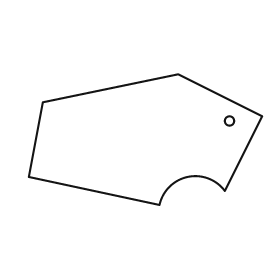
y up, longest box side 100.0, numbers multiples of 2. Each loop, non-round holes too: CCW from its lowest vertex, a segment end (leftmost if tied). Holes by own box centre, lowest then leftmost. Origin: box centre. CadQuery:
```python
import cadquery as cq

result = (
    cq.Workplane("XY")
    .moveTo(6.0, -28.0)
    .threePointArc((18.0, -16.0), (34.0, -22.0))
    .lineTo(50.0, 10.0)
    .lineTo(14.0, 28.0)
    .lineTo(-44.0, 16.0)
    .lineTo(-50.0, -16.0)
    .close()
    .moveTo(36.0, 8.0)
    .circle(2.0)
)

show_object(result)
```